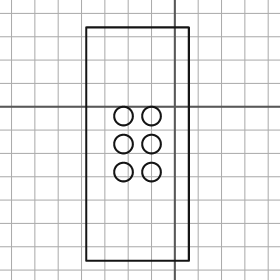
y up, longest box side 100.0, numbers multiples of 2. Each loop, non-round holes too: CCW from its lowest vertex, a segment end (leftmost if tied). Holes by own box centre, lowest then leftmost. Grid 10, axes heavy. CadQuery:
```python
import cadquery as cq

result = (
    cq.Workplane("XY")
    .moveTo(-38.0, -66.0)
    .lineTo(6.0, -66.0)
    .lineTo(6.0, 34.0)
    .lineTo(-38.0, 34.0)
    .close()
    .moveTo(-22.0, -28.0)
    .circle(4.0)
    .moveTo(-10.0, -28.0)
    .circle(4.0)
    .moveTo(-22.0, -16.0)
    .circle(4.0)
    .moveTo(-10.0, -16.0)
    .circle(4.0)
    .moveTo(-22.0, -4.0)
    .circle(4.0)
    .moveTo(-10.0, -4.0)
    .circle(4.0)
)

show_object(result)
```